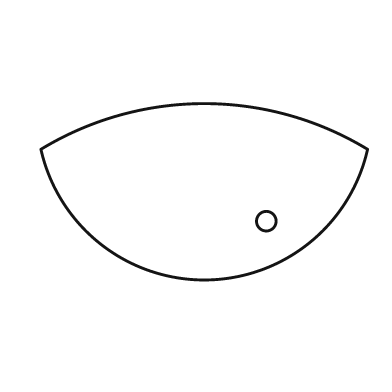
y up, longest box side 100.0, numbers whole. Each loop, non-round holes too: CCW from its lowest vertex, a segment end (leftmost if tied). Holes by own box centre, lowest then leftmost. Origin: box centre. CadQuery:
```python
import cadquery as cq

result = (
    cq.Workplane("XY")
    .moveTo(-50.0, 13.0)
    .threePointArc((0.0, -27.0), (50.0, 13.0))
    .threePointArc((0.0, 27.0), (-50.0, 13.0))
    .close()
    .moveTo(19.0, -9.0)
    .circle(3.0)
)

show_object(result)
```